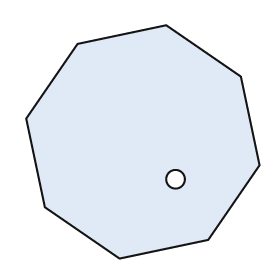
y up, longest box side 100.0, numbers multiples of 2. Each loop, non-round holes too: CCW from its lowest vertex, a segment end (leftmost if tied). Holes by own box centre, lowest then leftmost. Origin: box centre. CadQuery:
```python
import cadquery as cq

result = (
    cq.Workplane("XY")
    .moveTo(-10.0, -50.0)
    .lineTo(28.0, -42.0)
    .lineTo(50.0, -10.0)
    .lineTo(42.0, 28.0)
    .lineTo(10.0, 50.0)
    .lineTo(-28.0, 42.0)
    .lineTo(-50.0, 10.0)
    .lineTo(-42.0, -28.0)
    .close()
    .moveTo(14.0, -16.0)
    .circle(4.0)
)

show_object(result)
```